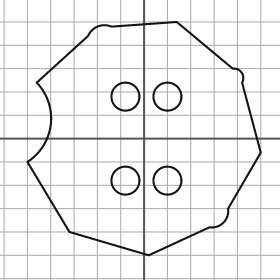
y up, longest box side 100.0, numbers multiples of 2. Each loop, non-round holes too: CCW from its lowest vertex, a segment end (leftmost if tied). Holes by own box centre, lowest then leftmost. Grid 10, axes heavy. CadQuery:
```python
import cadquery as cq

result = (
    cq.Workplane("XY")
    .moveTo(2.0, -50.0)
    .lineTo(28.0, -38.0)
    .threePointArc((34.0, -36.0), (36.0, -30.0))
    .lineTo(50.0, -6.0)
    .lineTo(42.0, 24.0)
    .threePointArc((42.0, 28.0), (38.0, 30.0))
    .lineTo(14.0, 50.0)
    .lineTo(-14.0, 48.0)
    .threePointArc((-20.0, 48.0), (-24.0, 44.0))
    .lineTo(-46.0, 24.0)
    .threePointArc((-40.0, 6.0), (-50.0, -10.0))
    .lineTo(-32.0, -40.0)
    .close()
    .moveTo(-8.0, -18.0)
    .circle(6.0)
    .moveTo(10.0, -18.0)
    .circle(6.0)
    .moveTo(-8.0, 18.0)
    .circle(6.0)
    .moveTo(10.0, 18.0)
    .circle(6.0)
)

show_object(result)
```